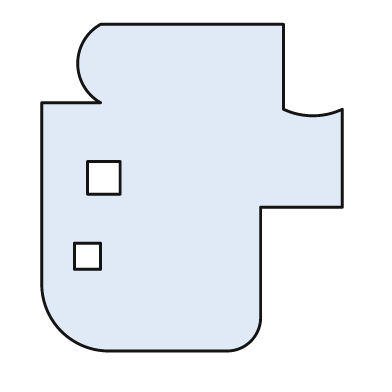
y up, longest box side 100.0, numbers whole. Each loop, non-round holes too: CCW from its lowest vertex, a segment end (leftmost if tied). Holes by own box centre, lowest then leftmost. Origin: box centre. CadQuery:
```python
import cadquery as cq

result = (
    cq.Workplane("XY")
    .moveTo(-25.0, -50.0)
    .lineTo(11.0, -50.0)
    .threePointArc((18.0, -47.0), (21.0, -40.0))
    .lineTo(21.0, -6.0)
    .lineTo(46.0, -6.0)
    .lineTo(46.0, 24.0)
    .threePointArc((37.0, 22.0), (28.0, 24.0))
    .lineTo(28.0, 50.0)
    .lineTo(-28.0, 50.0)
    .threePointArc((-35.0, 38.0), (-28.0, 26.0))
    .lineTo(-46.0, 26.0)
    .lineTo(-46.0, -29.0)
    .threePointArc((-40.0, -44.0), (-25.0, -50.0))
    .close()
    .moveTo(-36.0, -25.0)
    .lineTo(-28.0, -25.0)
    .lineTo(-28.0, -17.0)
    .lineTo(-36.0, -17.0)
    .close()
    .moveTo(-32.0, -2.0)
    .lineTo(-22.0, -2.0)
    .lineTo(-22.0, 8.0)
    .lineTo(-32.0, 8.0)
    .close()
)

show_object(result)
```